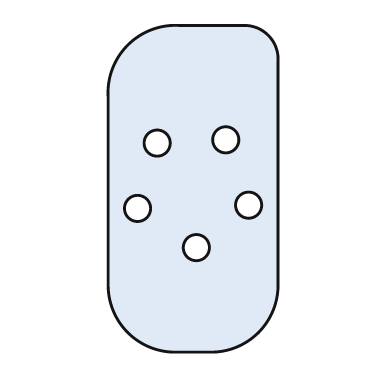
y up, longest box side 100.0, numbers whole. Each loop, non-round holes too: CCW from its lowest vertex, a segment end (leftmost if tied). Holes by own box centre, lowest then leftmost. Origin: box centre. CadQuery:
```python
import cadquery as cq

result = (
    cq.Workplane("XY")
    .moveTo(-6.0, -50.0)
    .lineTo(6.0, -50.0)
    .threePointArc((20.0, -44.0), (26.0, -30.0))
    .lineTo(26.0, 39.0)
    .threePointArc((23.0, 47.0), (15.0, 50.0))
    .lineTo(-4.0, 50.0)
    .threePointArc((-20.0, 44.0), (-26.0, 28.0))
    .lineTo(-26.0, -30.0)
    .threePointArc((-20.0, -44.0), (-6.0, -50.0))
    .close()
    .moveTo(1.0, -18.0)
    .circle(4.0)
    .moveTo(-17.0, -6.0)
    .circle(4.0)
    .moveTo(17.0, -5.0)
    .circle(4.0)
    .moveTo(-11.0, 14.0)
    .circle(4.0)
    .moveTo(10.0, 15.0)
    .circle(4.0)
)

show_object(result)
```